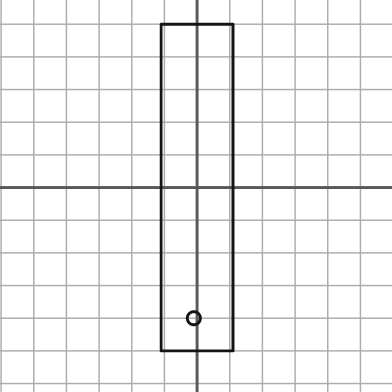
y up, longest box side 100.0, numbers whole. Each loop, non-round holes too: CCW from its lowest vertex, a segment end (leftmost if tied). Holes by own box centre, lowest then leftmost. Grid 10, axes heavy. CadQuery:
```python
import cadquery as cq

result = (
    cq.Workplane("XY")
    .moveTo(-11.0, -50.0)
    .lineTo(11.0, -50.0)
    .lineTo(11.0, 50.0)
    .lineTo(-11.0, 50.0)
    .close()
    .moveTo(-1.0, -40.0)
    .circle(2.0)
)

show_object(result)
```